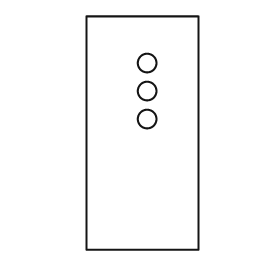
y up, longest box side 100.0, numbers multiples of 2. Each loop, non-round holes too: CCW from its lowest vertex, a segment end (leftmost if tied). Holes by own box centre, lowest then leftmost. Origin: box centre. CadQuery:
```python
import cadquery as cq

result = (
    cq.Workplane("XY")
    .moveTo(-24.0, -50.0)
    .lineTo(24.0, -50.0)
    .lineTo(24.0, 50.0)
    .lineTo(-24.0, 50.0)
    .close()
    .moveTo(2.0, 6.0)
    .circle(4.0)
    .moveTo(2.0, 18.0)
    .circle(4.0)
    .moveTo(2.0, 30.0)
    .circle(4.0)
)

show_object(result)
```